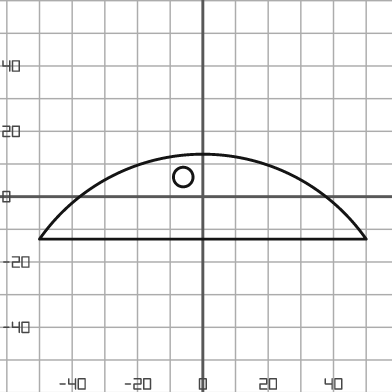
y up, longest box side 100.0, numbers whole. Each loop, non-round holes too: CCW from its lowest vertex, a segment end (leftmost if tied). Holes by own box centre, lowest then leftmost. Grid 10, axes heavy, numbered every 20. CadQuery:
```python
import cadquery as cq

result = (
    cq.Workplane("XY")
    .moveTo(-50.0, -13.0)
    .lineTo(50.0, -13.0)
    .threePointArc((0.0, 13.0), (-50.0, -13.0))
    .close()
    .moveTo(-6.0, 6.0)
    .circle(3.0)
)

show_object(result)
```